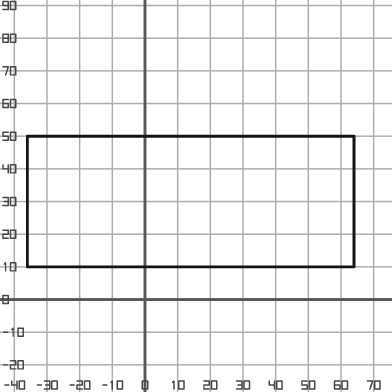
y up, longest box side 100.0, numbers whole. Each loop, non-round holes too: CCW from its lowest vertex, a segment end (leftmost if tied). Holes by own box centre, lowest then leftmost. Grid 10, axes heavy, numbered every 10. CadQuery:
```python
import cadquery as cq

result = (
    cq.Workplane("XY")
    .moveTo(-36.0, 10.0)
    .lineTo(64.0, 10.0)
    .lineTo(64.0, 50.0)
    .lineTo(-36.0, 50.0)
    .close()
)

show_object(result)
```